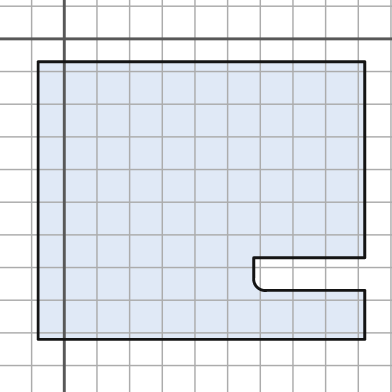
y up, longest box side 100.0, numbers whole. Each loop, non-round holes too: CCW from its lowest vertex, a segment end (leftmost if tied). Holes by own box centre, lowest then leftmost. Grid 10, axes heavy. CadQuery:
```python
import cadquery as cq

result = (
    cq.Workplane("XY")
    .moveTo(-8.0, -92.0)
    .lineTo(92.0, -92.0)
    .lineTo(92.0, -77.0)
    .lineTo(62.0, -77.0)
    .threePointArc((59.0, -76.0), (58.0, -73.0))
    .lineTo(58.0, -67.0)
    .lineTo(92.0, -67.0)
    .lineTo(92.0, -7.0)
    .lineTo(-8.0, -7.0)
    .close()
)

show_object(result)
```